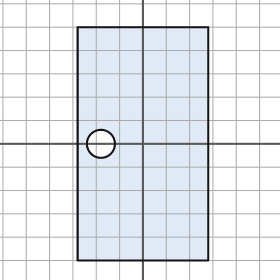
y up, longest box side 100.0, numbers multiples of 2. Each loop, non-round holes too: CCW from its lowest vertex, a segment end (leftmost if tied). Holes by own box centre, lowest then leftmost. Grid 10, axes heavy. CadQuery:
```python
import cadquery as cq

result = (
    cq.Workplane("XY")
    .moveTo(-28.0, -50.0)
    .lineTo(28.0, -50.0)
    .lineTo(28.0, 50.0)
    .lineTo(-28.0, 50.0)
    .close()
    .moveTo(-18.0, 0.0)
    .circle(6.0)
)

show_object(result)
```